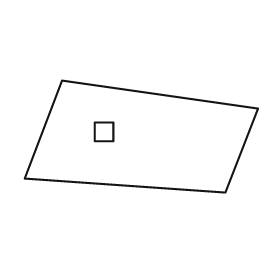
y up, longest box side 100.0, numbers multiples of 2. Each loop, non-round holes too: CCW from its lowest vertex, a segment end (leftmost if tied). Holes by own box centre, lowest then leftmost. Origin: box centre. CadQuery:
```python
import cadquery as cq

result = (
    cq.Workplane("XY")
    .moveTo(36.0, -24.0)
    .lineTo(50.0, 12.0)
    .lineTo(-34.0, 24.0)
    .lineTo(-50.0, -18.0)
    .close()
    .moveTo(-20.0, -2.0)
    .lineTo(-12.0, -2.0)
    .lineTo(-12.0, 6.0)
    .lineTo(-20.0, 6.0)
    .close()
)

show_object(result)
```